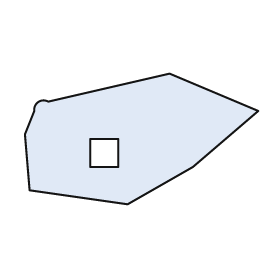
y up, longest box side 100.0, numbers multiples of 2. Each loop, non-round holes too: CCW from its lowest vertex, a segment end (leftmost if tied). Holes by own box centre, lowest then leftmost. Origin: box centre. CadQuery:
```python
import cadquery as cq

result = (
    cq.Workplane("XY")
    .moveTo(-6.0, -28.0)
    .lineTo(22.0, -12.0)
    .lineTo(50.0, 12.0)
    .lineTo(12.0, 28.0)
    .lineTo(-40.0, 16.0)
    .threePointArc((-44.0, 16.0), (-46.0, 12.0))
    .lineTo(-50.0, 2.0)
    .lineTo(-48.0, -22.0)
    .close()
    .moveTo(-22.0, -12.0)
    .lineTo(-10.0, -12.0)
    .lineTo(-10.0, 0.0)
    .lineTo(-22.0, 0.0)
    .close()
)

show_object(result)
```